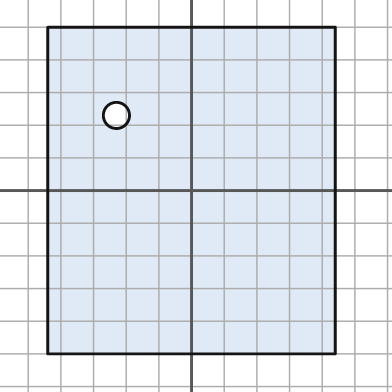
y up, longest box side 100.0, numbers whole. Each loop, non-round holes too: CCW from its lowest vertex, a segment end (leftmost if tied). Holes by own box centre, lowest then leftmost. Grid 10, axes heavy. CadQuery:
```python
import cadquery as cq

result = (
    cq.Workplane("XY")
    .moveTo(-44.0, -50.0)
    .lineTo(44.0, -50.0)
    .lineTo(44.0, 50.0)
    .lineTo(-44.0, 50.0)
    .close()
    .moveTo(-23.0, 23.0)
    .circle(4.0)
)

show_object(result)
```